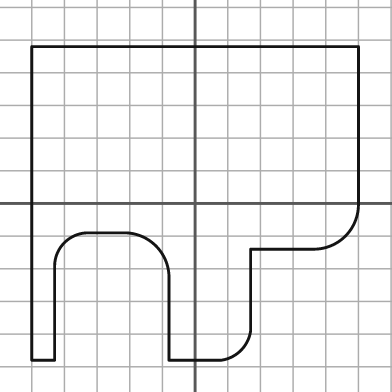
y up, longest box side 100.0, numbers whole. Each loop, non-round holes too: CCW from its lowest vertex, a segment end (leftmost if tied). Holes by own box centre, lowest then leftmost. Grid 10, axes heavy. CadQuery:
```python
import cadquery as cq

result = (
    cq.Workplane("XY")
    .moveTo(-50.0, -48.0)
    .lineTo(-43.0, -48.0)
    .lineTo(-43.0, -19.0)
    .threePointArc((-40.0, -12.0), (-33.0, -9.0))
    .lineTo(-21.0, -9.0)
    .threePointArc((-12.0, -13.0), (-8.0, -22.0))
    .lineTo(-8.0, -48.0)
    .lineTo(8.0, -48.0)
    .threePointArc((14.0, -45.0), (17.0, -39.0))
    .lineTo(17.0, -14.0)
    .lineTo(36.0, -14.0)
    .threePointArc((46.0, -10.0), (50.0, 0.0))
    .lineTo(50.0, 48.0)
    .lineTo(-50.0, 48.0)
    .close()
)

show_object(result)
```